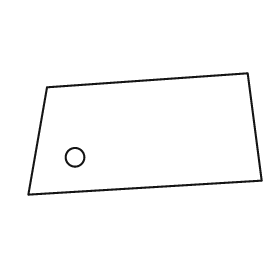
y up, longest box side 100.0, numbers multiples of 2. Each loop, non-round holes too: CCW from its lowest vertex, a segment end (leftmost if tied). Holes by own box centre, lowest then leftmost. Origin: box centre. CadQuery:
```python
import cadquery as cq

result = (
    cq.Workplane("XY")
    .moveTo(-50.0, -26.0)
    .lineTo(50.0, -20.0)
    .lineTo(44.0, 26.0)
    .lineTo(-42.0, 20.0)
    .close()
    .moveTo(-30.0, -10.0)
    .circle(4.0)
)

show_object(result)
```